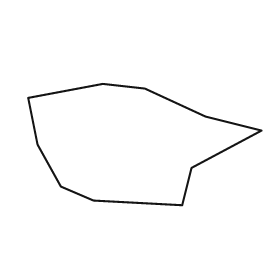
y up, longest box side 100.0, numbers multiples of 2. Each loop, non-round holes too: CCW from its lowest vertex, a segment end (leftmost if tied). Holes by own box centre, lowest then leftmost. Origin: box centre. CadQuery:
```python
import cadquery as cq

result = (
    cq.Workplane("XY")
    .moveTo(16.0, -26.0)
    .lineTo(20.0, -10.0)
    .lineTo(50.0, 6.0)
    .lineTo(26.0, 12.0)
    .lineTo(0.0, 24.0)
    .lineTo(-18.0, 26.0)
    .lineTo(-50.0, 20.0)
    .lineTo(-46.0, 0.0)
    .lineTo(-36.0, -18.0)
    .lineTo(-22.0, -24.0)
    .close()
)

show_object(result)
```